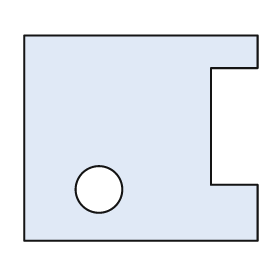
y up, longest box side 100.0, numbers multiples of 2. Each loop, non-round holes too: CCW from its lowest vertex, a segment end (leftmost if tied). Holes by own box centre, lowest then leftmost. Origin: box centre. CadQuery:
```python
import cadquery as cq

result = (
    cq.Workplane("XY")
    .moveTo(-50.0, -44.0)
    .lineTo(50.0, -44.0)
    .lineTo(50.0, -20.0)
    .lineTo(30.0, -20.0)
    .lineTo(30.0, 30.0)
    .lineTo(50.0, 30.0)
    .lineTo(50.0, 44.0)
    .lineTo(-50.0, 44.0)
    .close()
    .moveTo(-18.0, -22.0)
    .circle(10.0)
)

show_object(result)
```